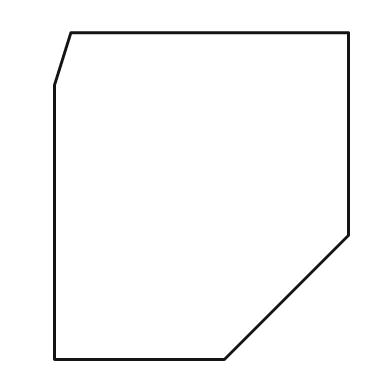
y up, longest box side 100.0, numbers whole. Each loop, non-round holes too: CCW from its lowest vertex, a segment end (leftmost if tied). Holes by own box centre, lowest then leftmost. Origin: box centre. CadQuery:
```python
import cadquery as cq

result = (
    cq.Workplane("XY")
    .moveTo(-45.0, -50.0)
    .lineTo(7.0, -50.0)
    .lineTo(45.0, -12.0)
    .lineTo(45.0, 50.0)
    .lineTo(-40.0, 50.0)
    .lineTo(-45.0, 34.0)
    .close()
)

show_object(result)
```